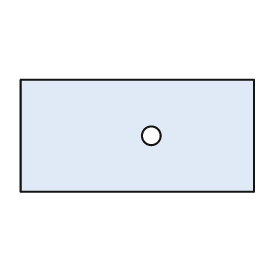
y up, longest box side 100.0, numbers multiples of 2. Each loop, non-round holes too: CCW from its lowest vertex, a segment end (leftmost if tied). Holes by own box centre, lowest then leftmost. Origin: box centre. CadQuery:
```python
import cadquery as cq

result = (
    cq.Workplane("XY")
    .moveTo(-50.0, -24.0)
    .lineTo(50.0, -24.0)
    .lineTo(50.0, 24.0)
    .lineTo(-50.0, 24.0)
    .close()
    .moveTo(6.0, 0.0)
    .circle(4.0)
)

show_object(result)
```